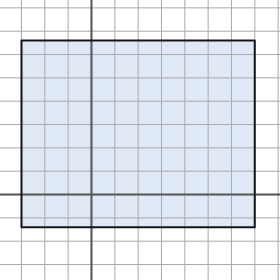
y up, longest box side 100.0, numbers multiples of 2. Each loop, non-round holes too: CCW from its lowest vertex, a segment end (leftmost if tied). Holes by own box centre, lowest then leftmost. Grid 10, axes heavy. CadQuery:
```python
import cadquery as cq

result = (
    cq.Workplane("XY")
    .moveTo(-30.0, -14.0)
    .lineTo(70.0, -14.0)
    .lineTo(70.0, 66.0)
    .lineTo(-30.0, 66.0)
    .close()
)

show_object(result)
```